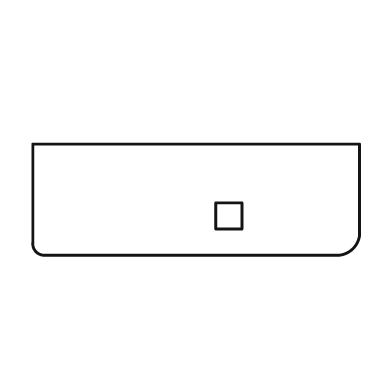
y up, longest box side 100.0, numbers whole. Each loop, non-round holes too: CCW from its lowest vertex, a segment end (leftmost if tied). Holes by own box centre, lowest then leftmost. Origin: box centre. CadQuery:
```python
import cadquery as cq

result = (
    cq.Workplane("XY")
    .moveTo(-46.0, -17.0)
    .lineTo(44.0, -17.0)
    .threePointArc((48.0, -15.0), (50.0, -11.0))
    .lineTo(50.0, 17.0)
    .lineTo(-50.0, 17.0)
    .lineTo(-50.0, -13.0)
    .threePointArc((-49.0, -16.0), (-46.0, -17.0))
    .close()
    .moveTo(6.0, -9.0)
    .lineTo(14.0, -9.0)
    .lineTo(14.0, -1.0)
    .lineTo(6.0, -1.0)
    .close()
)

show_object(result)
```